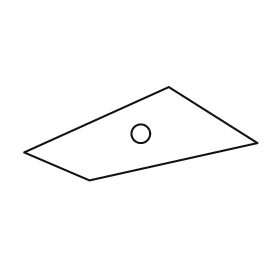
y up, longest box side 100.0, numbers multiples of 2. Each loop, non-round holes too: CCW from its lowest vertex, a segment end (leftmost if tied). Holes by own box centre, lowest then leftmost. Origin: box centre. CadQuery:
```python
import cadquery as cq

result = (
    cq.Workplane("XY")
    .moveTo(-22.0, -20.0)
    .lineTo(50.0, -4.0)
    .lineTo(12.0, 20.0)
    .lineTo(-50.0, -8.0)
    .close()
    .moveTo(0.0, 0.0)
    .circle(4.0)
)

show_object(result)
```